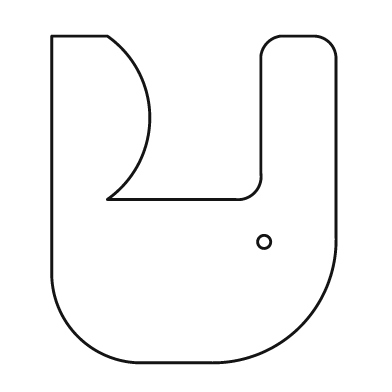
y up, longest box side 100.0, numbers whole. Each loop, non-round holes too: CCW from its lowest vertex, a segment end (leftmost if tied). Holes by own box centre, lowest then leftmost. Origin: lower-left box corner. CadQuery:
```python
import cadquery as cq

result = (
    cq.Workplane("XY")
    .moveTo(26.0, 0.0)
    .lineTo(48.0, 0.0)
    .threePointArc((76.0, 11.0), (87.0, 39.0))
    .lineTo(87.0, 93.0)
    .threePointArc((85.0, 98.0), (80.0, 100.0))
    .lineTo(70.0, 100.0)
    .threePointArc((66.0, 98.0), (64.0, 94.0))
    .lineTo(64.0, 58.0)
    .threePointArc((62.0, 52.0), (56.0, 50.0))
    .lineTo(17.0, 50.0)
    .threePointArc((30.0, 75.0), (17.0, 100.0))
    .lineTo(0.0, 100.0)
    .lineTo(0.0, 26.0)
    .threePointArc((8.0, 8.0), (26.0, 0.0))
    .close()
    .moveTo(65.0, 37.0)
    .circle(2.0)
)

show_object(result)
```